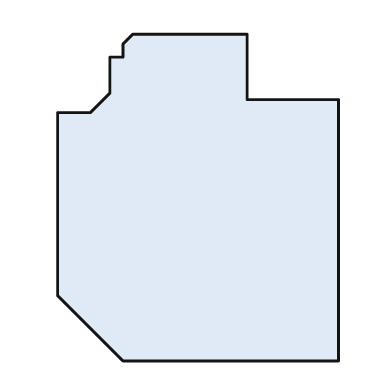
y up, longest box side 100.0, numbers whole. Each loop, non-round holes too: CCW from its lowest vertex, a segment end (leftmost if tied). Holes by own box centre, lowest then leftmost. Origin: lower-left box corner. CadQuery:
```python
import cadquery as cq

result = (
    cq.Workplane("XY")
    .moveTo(20.0, 0.0)
    .lineTo(86.0, 0.0)
    .lineTo(86.0, 80.0)
    .lineTo(58.0, 80.0)
    .lineTo(58.0, 100.0)
    .lineTo(23.0, 100.0)
    .lineTo(20.0, 97.0)
    .lineTo(20.0, 93.0)
    .lineTo(16.0, 93.0)
    .lineTo(16.0, 82.0)
    .lineTo(10.0, 76.0)
    .lineTo(0.0, 76.0)
    .lineTo(0.0, 20.0)
    .close()
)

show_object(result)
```